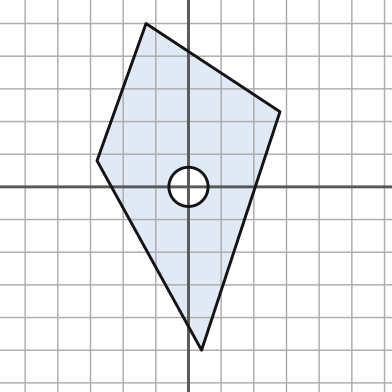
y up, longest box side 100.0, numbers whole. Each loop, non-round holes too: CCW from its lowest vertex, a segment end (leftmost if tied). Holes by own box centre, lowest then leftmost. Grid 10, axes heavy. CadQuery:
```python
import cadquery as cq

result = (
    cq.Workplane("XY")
    .moveTo(4.0, -50.0)
    .lineTo(28.0, 23.0)
    .lineTo(-13.0, 50.0)
    .lineTo(-28.0, 8.0)
    .close()
    .moveTo(0.0, 0.0)
    .circle(6.0)
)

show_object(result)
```